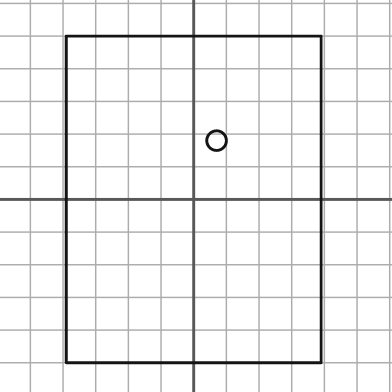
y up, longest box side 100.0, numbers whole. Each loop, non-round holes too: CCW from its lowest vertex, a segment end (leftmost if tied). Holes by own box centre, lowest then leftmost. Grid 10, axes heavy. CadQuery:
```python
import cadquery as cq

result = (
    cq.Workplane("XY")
    .moveTo(-39.0, -50.0)
    .lineTo(39.0, -50.0)
    .lineTo(39.0, 50.0)
    .lineTo(-39.0, 50.0)
    .close()
    .moveTo(7.0, 18.0)
    .circle(3.0)
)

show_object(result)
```